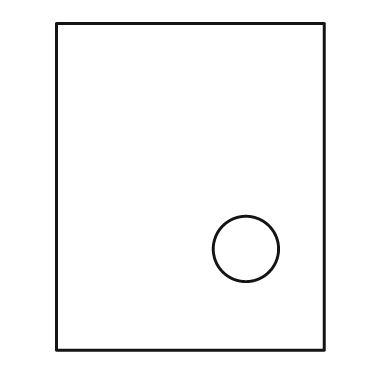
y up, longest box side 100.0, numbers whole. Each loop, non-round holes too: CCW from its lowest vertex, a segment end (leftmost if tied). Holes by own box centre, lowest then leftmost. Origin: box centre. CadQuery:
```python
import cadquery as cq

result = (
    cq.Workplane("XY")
    .moveTo(-41.0, -50.0)
    .lineTo(41.0, -50.0)
    .lineTo(41.0, 50.0)
    .lineTo(-41.0, 50.0)
    .close()
    .moveTo(17.0, -19.0)
    .circle(10.0)
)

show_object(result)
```